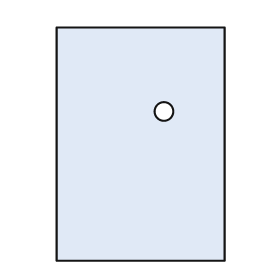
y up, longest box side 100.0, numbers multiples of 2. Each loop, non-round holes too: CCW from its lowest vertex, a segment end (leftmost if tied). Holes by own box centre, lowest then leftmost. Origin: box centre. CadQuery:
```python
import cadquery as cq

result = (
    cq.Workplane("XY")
    .moveTo(-36.0, -50.0)
    .lineTo(36.0, -50.0)
    .lineTo(36.0, 50.0)
    .lineTo(-36.0, 50.0)
    .close()
    .moveTo(10.0, 14.0)
    .circle(4.0)
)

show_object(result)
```